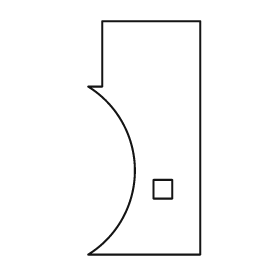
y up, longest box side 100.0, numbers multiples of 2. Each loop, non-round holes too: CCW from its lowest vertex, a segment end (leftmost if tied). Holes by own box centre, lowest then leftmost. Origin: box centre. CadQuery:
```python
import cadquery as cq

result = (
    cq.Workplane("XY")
    .moveTo(-24.0, -50.0)
    .lineTo(24.0, -50.0)
    .lineTo(24.0, 50.0)
    .lineTo(-18.0, 50.0)
    .lineTo(-18.0, 22.0)
    .lineTo(-24.0, 22.0)
    .threePointArc((-4.0, -14.0), (-24.0, -50.0))
    .close()
    .moveTo(4.0, -26.0)
    .lineTo(12.0, -26.0)
    .lineTo(12.0, -18.0)
    .lineTo(4.0, -18.0)
    .close()
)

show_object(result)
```